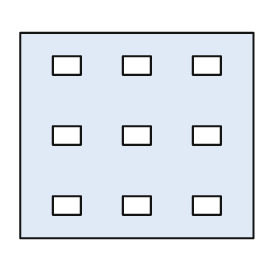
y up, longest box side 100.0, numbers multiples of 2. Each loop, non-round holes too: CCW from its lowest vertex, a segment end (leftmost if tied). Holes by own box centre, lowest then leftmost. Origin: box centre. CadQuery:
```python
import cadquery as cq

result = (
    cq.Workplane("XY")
    .moveTo(-50.0, -44.0)
    .lineTo(50.0, -44.0)
    .lineTo(50.0, 44.0)
    .lineTo(-50.0, 44.0)
    .close()
    .moveTo(-36.0, -34.0)
    .lineTo(-24.0, -34.0)
    .lineTo(-24.0, -26.0)
    .lineTo(-36.0, -26.0)
    .close()
    .moveTo(-6.0, -34.0)
    .lineTo(6.0, -34.0)
    .lineTo(6.0, -26.0)
    .lineTo(-6.0, -26.0)
    .close()
    .moveTo(24.0, -34.0)
    .lineTo(36.0, -34.0)
    .lineTo(36.0, -26.0)
    .lineTo(24.0, -26.0)
    .close()
    .moveTo(-36.0, -4.0)
    .lineTo(-24.0, -4.0)
    .lineTo(-24.0, 4.0)
    .lineTo(-36.0, 4.0)
    .close()
    .moveTo(-6.0, -4.0)
    .lineTo(6.0, -4.0)
    .lineTo(6.0, 4.0)
    .lineTo(-6.0, 4.0)
    .close()
    .moveTo(24.0, -4.0)
    .lineTo(36.0, -4.0)
    .lineTo(36.0, 4.0)
    .lineTo(24.0, 4.0)
    .close()
    .moveTo(-36.0, 26.0)
    .lineTo(-24.0, 26.0)
    .lineTo(-24.0, 34.0)
    .lineTo(-36.0, 34.0)
    .close()
    .moveTo(-6.0, 26.0)
    .lineTo(6.0, 26.0)
    .lineTo(6.0, 34.0)
    .lineTo(-6.0, 34.0)
    .close()
    .moveTo(24.0, 26.0)
    .lineTo(36.0, 26.0)
    .lineTo(36.0, 34.0)
    .lineTo(24.0, 34.0)
    .close()
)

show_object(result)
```